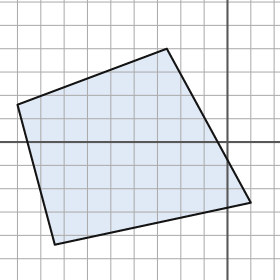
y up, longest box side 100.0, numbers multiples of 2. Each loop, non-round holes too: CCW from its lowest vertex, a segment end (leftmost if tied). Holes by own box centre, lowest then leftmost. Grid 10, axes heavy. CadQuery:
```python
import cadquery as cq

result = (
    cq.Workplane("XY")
    .moveTo(-74.0, -44.0)
    .lineTo(10.0, -26.0)
    .lineTo(-26.0, 40.0)
    .lineTo(-90.0, 16.0)
    .close()
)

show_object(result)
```